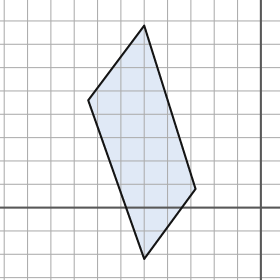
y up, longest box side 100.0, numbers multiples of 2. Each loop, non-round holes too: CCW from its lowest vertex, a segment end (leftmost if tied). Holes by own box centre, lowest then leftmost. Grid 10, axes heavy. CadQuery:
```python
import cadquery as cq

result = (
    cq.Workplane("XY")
    .moveTo(-50.0, -22.0)
    .lineTo(-28.0, 8.0)
    .lineTo(-50.0, 78.0)
    .lineTo(-74.0, 46.0)
    .close()
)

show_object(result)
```